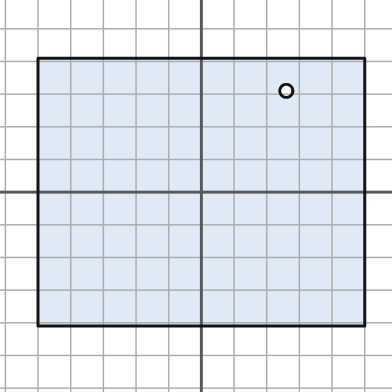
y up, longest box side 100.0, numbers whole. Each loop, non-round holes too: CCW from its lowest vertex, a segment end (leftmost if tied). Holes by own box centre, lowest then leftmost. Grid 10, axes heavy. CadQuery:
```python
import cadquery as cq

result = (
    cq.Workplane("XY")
    .moveTo(-50.0, -41.0)
    .lineTo(50.0, -41.0)
    .lineTo(50.0, 41.0)
    .lineTo(-50.0, 41.0)
    .close()
    .moveTo(26.0, 31.0)
    .circle(2.0)
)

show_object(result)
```